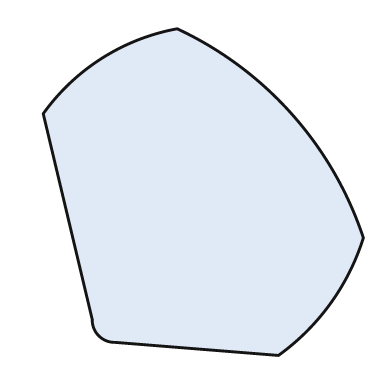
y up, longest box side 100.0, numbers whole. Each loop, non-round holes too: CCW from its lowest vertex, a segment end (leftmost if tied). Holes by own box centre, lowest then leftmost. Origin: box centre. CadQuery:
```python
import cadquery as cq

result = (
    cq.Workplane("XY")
    .moveTo(23.0, -50.0)
    .threePointArc((39.0, -34.0), (49.0, -14.0))
    .threePointArc((27.0, 24.0), (-8.0, 50.0))
    .threePointArc((-31.0, 41.0), (-49.0, 24.0))
    .lineTo(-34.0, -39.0)
    .threePointArc((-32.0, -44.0), (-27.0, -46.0))
    .close()
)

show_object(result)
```